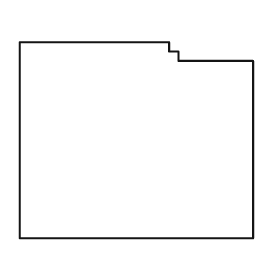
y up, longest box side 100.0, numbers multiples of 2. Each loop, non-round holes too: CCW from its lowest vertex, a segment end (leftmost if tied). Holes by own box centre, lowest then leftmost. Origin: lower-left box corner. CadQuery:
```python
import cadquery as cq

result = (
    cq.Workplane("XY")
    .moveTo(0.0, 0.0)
    .lineTo(100.0, 0.0)
    .lineTo(100.0, 76.0)
    .lineTo(68.0, 76.0)
    .lineTo(68.0, 80.0)
    .lineTo(64.0, 80.0)
    .lineTo(64.0, 84.0)
    .lineTo(0.0, 84.0)
    .close()
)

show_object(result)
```